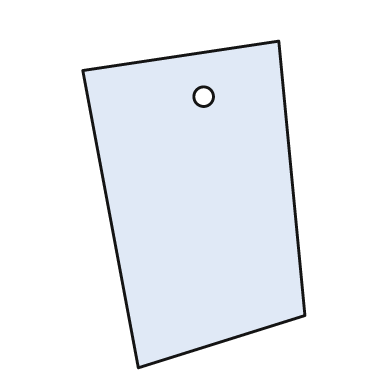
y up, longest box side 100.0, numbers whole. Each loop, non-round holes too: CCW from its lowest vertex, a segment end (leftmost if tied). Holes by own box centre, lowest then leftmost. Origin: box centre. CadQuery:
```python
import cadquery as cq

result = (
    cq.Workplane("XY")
    .moveTo(-17.0, -50.0)
    .lineTo(34.0, -34.0)
    .lineTo(26.0, 50.0)
    .lineTo(-34.0, 41.0)
    .close()
    .moveTo(3.0, 33.0)
    .circle(3.0)
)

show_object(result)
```